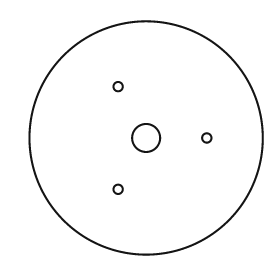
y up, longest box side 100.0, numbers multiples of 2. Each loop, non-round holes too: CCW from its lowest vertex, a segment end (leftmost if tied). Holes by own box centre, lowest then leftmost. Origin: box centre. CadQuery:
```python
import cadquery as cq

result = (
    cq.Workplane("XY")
    .moveTo(0.0, 0.0)
    .circle(50.0)
    .moveTo(-12.0, -22.0)
    .circle(2.0)
    .moveTo(0.0, 0.0)
    .circle(6.0)
    .moveTo(26.0, 0.0)
    .circle(2.0)
    .moveTo(-12.0, 22.0)
    .circle(2.0)
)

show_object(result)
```